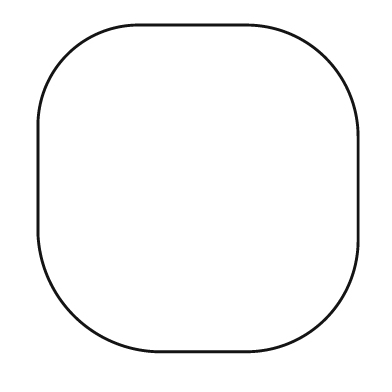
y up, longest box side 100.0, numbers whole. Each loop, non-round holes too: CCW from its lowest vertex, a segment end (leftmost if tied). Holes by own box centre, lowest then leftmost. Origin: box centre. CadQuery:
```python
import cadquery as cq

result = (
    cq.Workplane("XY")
    .moveTo(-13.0, -50.0)
    .lineTo(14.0, -50.0)
    .threePointArc((39.0, -40.0), (49.0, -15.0))
    .lineTo(49.0, 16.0)
    .threePointArc((39.0, 40.0), (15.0, 50.0))
    .lineTo(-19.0, 50.0)
    .threePointArc((-40.0, 41.0), (-49.0, 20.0))
    .lineTo(-49.0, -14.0)
    .threePointArc((-38.0, -39.0), (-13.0, -50.0))
    .close()
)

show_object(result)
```